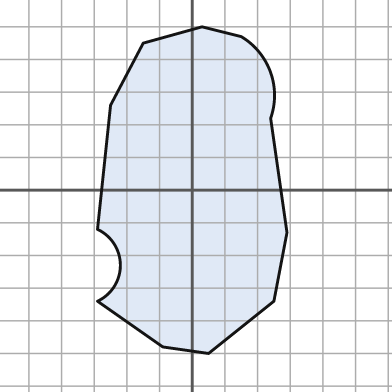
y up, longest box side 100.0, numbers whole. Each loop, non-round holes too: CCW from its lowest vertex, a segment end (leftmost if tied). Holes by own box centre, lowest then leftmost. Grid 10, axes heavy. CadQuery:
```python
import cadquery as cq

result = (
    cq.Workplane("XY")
    .moveTo(5.0, -50.0)
    .lineTo(25.0, -34.0)
    .lineTo(29.0, -13.0)
    .lineTo(24.0, 22.0)
    .threePointArc((24.0, 36.0), (15.0, 47.0))
    .lineTo(3.0, 50.0)
    .lineTo(-15.0, 45.0)
    .lineTo(-25.0, 26.0)
    .lineTo(-29.0, -12.0)
    .threePointArc((-22.0, -23.0), (-29.0, -34.0))
    .lineTo(-9.0, -48.0)
    .close()
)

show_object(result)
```